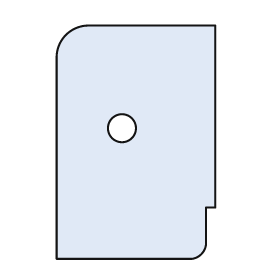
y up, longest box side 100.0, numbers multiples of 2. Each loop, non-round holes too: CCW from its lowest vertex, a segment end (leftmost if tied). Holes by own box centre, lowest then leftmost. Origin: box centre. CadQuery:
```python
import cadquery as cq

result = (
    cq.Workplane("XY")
    .moveTo(-34.0, -50.0)
    .lineTo(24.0, -50.0)
    .threePointArc((28.0, -48.0), (30.0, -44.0))
    .lineTo(30.0, -28.0)
    .lineTo(34.0, -28.0)
    .lineTo(34.0, 50.0)
    .lineTo(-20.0, 50.0)
    .threePointArc((-30.0, 46.0), (-34.0, 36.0))
    .close()
    .moveTo(-6.0, 6.0)
    .circle(6.0)
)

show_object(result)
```